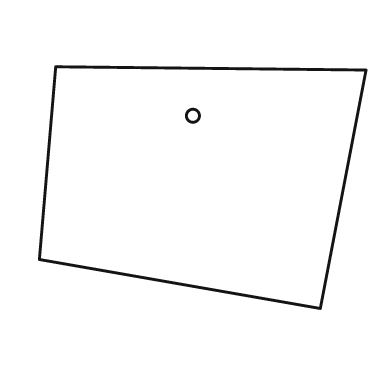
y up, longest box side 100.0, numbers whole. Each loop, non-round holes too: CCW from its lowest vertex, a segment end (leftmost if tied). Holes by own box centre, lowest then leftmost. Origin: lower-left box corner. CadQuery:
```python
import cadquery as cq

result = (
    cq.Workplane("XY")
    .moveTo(86.0, 0.0)
    .lineTo(100.0, 73.0)
    .lineTo(5.0, 74.0)
    .lineTo(0.0, 15.0)
    .close()
    .moveTo(47.0, 59.0)
    .circle(2.0)
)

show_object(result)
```